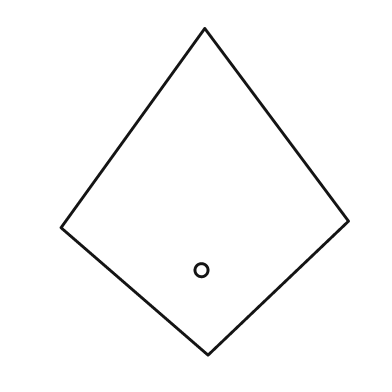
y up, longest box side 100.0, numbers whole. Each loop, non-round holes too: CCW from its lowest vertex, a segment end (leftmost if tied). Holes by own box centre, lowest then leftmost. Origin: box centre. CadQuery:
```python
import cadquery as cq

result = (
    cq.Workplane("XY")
    .moveTo(1.0, -50.0)
    .lineTo(44.0, -9.0)
    .lineTo(0.0, 50.0)
    .lineTo(-44.0, -11.0)
    .close()
    .moveTo(-1.0, -24.0)
    .circle(2.0)
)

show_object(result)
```